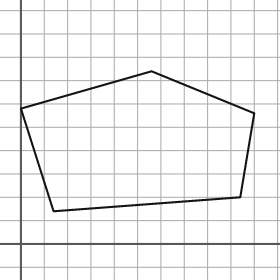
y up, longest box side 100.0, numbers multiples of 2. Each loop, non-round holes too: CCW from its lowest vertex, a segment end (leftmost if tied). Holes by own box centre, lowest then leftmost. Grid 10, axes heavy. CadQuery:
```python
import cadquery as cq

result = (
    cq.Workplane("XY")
    .moveTo(14.0, 14.0)
    .lineTo(94.0, 20.0)
    .lineTo(100.0, 56.0)
    .lineTo(56.0, 74.0)
    .lineTo(0.0, 58.0)
    .close()
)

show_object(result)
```